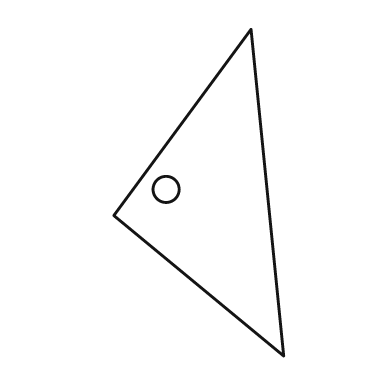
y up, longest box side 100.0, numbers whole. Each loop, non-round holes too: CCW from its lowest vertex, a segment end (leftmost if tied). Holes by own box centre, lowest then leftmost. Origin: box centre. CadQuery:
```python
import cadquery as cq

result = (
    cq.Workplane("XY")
    .moveTo(26.0, -50.0)
    .lineTo(16.0, 50.0)
    .lineTo(-26.0, -7.0)
    .close()
    .moveTo(-10.0, 1.0)
    .circle(4.0)
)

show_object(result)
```